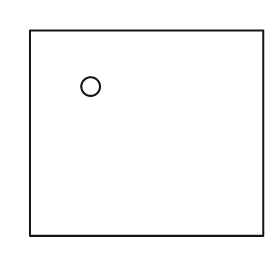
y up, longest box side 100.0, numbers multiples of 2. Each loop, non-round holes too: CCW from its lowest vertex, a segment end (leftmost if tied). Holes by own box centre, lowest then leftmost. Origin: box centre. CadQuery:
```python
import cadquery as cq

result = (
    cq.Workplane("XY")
    .moveTo(-50.0, -44.0)
    .lineTo(50.0, -44.0)
    .lineTo(50.0, 44.0)
    .lineTo(-50.0, 44.0)
    .close()
    .moveTo(-24.0, 20.0)
    .circle(4.0)
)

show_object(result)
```